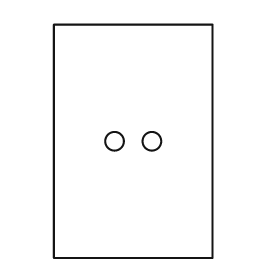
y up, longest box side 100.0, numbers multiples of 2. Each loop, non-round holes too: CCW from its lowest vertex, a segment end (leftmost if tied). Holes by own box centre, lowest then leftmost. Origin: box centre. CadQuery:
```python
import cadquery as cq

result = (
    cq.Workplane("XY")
    .moveTo(-34.0, -50.0)
    .lineTo(34.0, -50.0)
    .lineTo(34.0, 50.0)
    .lineTo(-34.0, 50.0)
    .close()
    .moveTo(-8.0, 0.0)
    .circle(4.0)
    .moveTo(8.0, 0.0)
    .circle(4.0)
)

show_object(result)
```